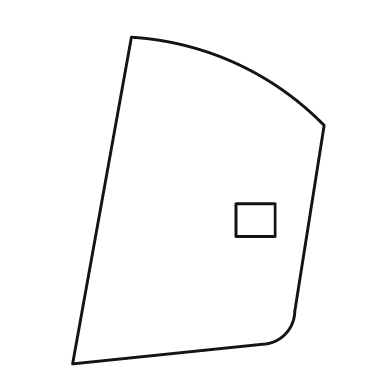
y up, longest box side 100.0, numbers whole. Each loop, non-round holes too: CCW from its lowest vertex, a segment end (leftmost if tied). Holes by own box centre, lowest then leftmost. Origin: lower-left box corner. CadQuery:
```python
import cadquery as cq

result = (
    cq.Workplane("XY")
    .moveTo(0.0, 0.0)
    .lineTo(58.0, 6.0)
    .threePointArc((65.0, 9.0), (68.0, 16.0))
    .lineTo(77.0, 73.0)
    .threePointArc((50.0, 92.0), (18.0, 100.0))
    .close()
    .moveTo(50.0, 39.0)
    .lineTo(62.0, 39.0)
    .lineTo(62.0, 49.0)
    .lineTo(50.0, 49.0)
    .close()
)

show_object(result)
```